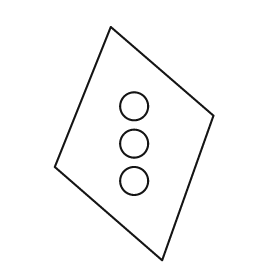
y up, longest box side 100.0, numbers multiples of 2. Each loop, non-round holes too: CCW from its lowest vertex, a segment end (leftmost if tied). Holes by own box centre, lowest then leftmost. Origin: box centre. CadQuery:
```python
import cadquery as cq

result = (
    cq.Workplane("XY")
    .moveTo(12.0, -50.0)
    .lineTo(34.0, 12.0)
    .lineTo(-10.0, 50.0)
    .lineTo(-34.0, -10.0)
    .close()
    .moveTo(0.0, -16.0)
    .circle(6.0)
    .moveTo(0.0, 0.0)
    .circle(6.0)
    .moveTo(0.0, 16.0)
    .circle(6.0)
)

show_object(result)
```